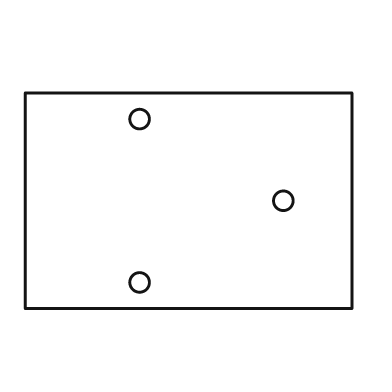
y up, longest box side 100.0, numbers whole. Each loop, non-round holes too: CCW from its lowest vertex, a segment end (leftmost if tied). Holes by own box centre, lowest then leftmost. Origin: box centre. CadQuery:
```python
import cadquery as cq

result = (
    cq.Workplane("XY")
    .moveTo(-50.0, -33.0)
    .lineTo(50.0, -33.0)
    .lineTo(50.0, 33.0)
    .lineTo(-50.0, 33.0)
    .close()
    .moveTo(-15.0, -25.0)
    .circle(3.0)
    .moveTo(29.0, 0.0)
    .circle(3.0)
    .moveTo(-15.0, 25.0)
    .circle(3.0)
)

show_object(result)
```